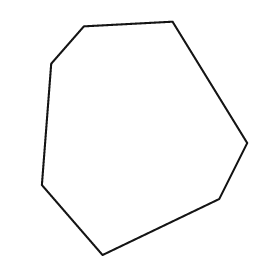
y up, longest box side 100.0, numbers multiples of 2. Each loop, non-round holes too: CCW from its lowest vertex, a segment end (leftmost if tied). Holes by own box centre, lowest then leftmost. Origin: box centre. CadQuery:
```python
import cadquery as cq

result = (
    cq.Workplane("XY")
    .moveTo(-18.0, -50.0)
    .lineTo(32.0, -26.0)
    .lineTo(44.0, -2.0)
    .lineTo(12.0, 50.0)
    .lineTo(-26.0, 48.0)
    .lineTo(-40.0, 32.0)
    .lineTo(-44.0, -20.0)
    .close()
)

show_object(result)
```